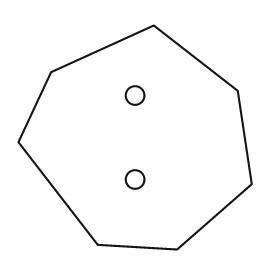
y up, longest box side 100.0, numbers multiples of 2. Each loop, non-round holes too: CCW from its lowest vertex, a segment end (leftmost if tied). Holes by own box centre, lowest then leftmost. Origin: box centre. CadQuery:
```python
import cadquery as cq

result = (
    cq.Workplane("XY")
    .moveTo(18.0, -48.0)
    .lineTo(50.0, -20.0)
    .lineTo(44.0, 20.0)
    .lineTo(8.0, 48.0)
    .lineTo(-36.0, 28.0)
    .lineTo(-50.0, -2.0)
    .lineTo(-16.0, -46.0)
    .close()
    .moveTo(0.0, -18.0)
    .circle(4.0)
    .moveTo(0.0, 18.0)
    .circle(4.0)
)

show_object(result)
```